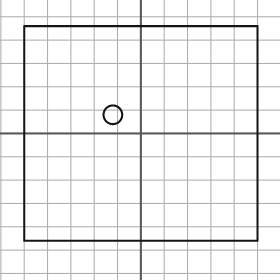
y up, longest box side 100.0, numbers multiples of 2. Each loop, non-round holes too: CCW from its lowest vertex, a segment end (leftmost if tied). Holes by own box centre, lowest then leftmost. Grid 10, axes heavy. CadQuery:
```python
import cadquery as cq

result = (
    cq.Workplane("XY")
    .moveTo(-50.0, -46.0)
    .lineTo(50.0, -46.0)
    .lineTo(50.0, 46.0)
    .lineTo(-50.0, 46.0)
    .close()
    .moveTo(-12.0, 8.0)
    .circle(4.0)
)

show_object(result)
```